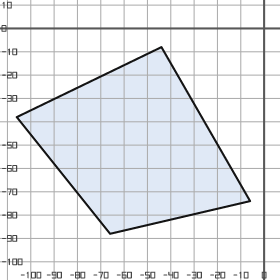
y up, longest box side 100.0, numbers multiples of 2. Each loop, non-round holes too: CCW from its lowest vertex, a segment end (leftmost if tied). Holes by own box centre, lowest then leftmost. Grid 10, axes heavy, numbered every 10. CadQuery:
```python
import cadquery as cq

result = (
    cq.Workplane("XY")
    .moveTo(-66.0, -88.0)
    .lineTo(-6.0, -74.0)
    .lineTo(-44.0, -8.0)
    .lineTo(-106.0, -38.0)
    .close()
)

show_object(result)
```